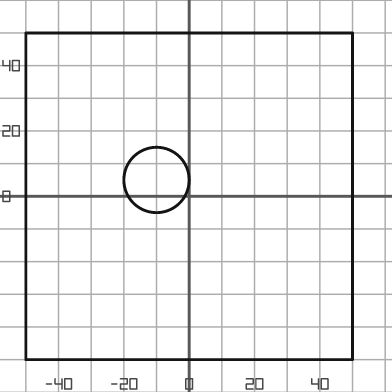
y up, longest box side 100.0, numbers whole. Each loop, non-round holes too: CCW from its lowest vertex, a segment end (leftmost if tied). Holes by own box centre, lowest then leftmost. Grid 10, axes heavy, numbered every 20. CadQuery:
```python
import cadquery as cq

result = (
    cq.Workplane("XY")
    .moveTo(-50.0, -50.0)
    .lineTo(50.0, -50.0)
    .lineTo(50.0, 50.0)
    .lineTo(-50.0, 50.0)
    .close()
    .moveTo(-10.0, 5.0)
    .circle(10.0)
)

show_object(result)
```